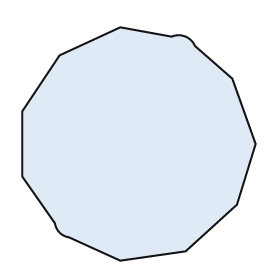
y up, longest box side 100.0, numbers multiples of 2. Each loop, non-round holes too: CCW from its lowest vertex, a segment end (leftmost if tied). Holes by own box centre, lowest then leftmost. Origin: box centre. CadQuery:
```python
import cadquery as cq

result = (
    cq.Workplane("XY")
    .moveTo(-8.0, -50.0)
    .lineTo(20.0, -46.0)
    .lineTo(42.0, -26.0)
    .lineTo(50.0, 0.0)
    .lineTo(40.0, 28.0)
    .lineTo(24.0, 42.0)
    .threePointArc((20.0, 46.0), (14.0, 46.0))
    .lineTo(-8.0, 50.0)
    .lineTo(-34.0, 38.0)
    .lineTo(-50.0, 14.0)
    .lineTo(-50.0, -14.0)
    .lineTo(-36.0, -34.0)
    .threePointArc((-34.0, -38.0), (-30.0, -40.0))
    .close()
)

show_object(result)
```